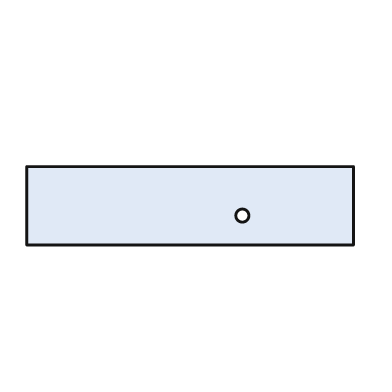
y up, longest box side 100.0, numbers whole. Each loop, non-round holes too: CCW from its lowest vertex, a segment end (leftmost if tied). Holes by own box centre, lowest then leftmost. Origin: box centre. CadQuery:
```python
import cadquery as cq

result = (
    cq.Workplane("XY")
    .moveTo(-50.0, -12.0)
    .lineTo(50.0, -12.0)
    .lineTo(50.0, 12.0)
    .lineTo(-50.0, 12.0)
    .close()
    .moveTo(16.0, -3.0)
    .circle(2.0)
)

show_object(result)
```